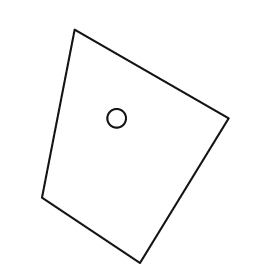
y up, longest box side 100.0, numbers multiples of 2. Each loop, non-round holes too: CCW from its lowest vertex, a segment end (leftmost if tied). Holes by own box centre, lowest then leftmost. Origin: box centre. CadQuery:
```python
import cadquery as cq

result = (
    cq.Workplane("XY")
    .moveTo(2.0, -50.0)
    .lineTo(40.0, 12.0)
    .lineTo(-26.0, 50.0)
    .lineTo(-40.0, -22.0)
    .close()
    .moveTo(-8.0, 12.0)
    .circle(4.0)
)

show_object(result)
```